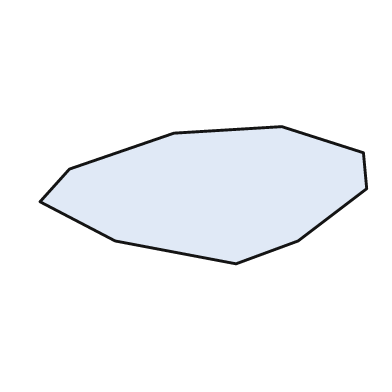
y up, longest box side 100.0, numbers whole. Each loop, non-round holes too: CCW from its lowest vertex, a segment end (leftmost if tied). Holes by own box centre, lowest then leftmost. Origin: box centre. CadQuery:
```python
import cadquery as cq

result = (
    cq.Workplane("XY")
    .moveTo(10.0, -21.0)
    .lineTo(29.0, -14.0)
    .lineTo(50.0, 2.0)
    .lineTo(49.0, 13.0)
    .lineTo(24.0, 21.0)
    .lineTo(-9.0, 19.0)
    .lineTo(-41.0, 8.0)
    .lineTo(-50.0, -2.0)
    .lineTo(-27.0, -14.0)
    .close()
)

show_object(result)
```